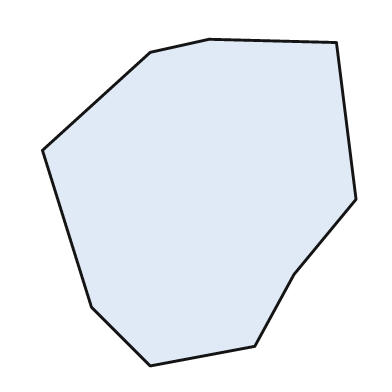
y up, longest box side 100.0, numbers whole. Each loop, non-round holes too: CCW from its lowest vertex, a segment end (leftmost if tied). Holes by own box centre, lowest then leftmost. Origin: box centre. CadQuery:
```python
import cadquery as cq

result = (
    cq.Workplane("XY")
    .moveTo(-15.0, -50.0)
    .lineTo(17.0, -44.0)
    .lineTo(29.0, -22.0)
    .lineTo(48.0, 1.0)
    .lineTo(42.0, 49.0)
    .lineTo(3.0, 50.0)
    .lineTo(-15.0, 46.0)
    .lineTo(-48.0, 16.0)
    .lineTo(-33.0, -32.0)
    .close()
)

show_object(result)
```